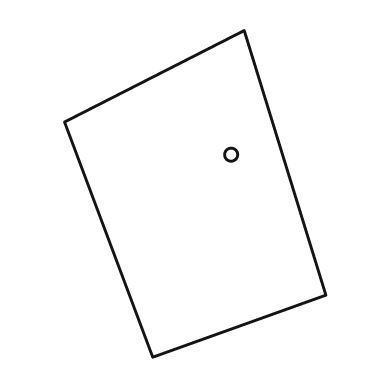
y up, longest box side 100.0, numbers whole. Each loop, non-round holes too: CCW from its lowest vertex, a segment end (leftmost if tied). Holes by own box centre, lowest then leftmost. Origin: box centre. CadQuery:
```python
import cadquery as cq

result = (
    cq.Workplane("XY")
    .moveTo(-13.0, -50.0)
    .lineTo(40.0, -31.0)
    .lineTo(15.0, 50.0)
    .lineTo(-40.0, 22.0)
    .close()
    .moveTo(11.0, 12.0)
    .circle(2.0)
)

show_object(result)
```